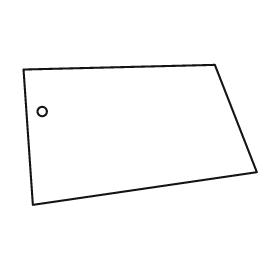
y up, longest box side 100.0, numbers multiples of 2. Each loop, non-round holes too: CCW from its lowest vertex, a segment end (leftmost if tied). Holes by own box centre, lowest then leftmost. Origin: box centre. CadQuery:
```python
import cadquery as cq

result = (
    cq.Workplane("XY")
    .moveTo(-46.0, -30.0)
    .lineTo(50.0, -16.0)
    .lineTo(32.0, 30.0)
    .lineTo(-50.0, 28.0)
    .close()
    .moveTo(-42.0, 10.0)
    .circle(2.0)
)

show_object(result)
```